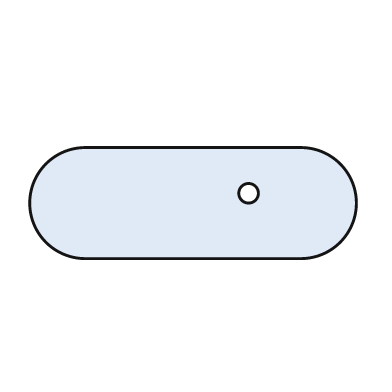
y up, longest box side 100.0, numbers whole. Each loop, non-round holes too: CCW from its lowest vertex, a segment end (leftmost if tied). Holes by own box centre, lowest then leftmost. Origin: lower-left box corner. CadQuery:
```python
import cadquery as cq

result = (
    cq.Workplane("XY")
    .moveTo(17.0, 0.0)
    .lineTo(83.0, 0.0)
    .threePointArc((100.0, 17.0), (83.0, 34.0))
    .lineTo(17.0, 34.0)
    .threePointArc((0.0, 17.0), (17.0, 0.0))
    .close()
    .moveTo(67.0, 20.0)
    .circle(3.0)
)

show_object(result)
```